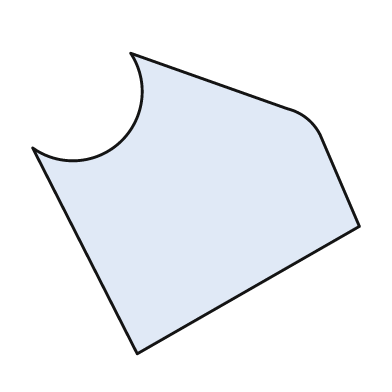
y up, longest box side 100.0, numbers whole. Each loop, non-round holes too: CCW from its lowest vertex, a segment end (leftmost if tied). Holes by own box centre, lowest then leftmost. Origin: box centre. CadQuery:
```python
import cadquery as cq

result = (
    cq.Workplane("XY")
    .moveTo(-18.0, -46.0)
    .lineTo(50.0, -7.0)
    .lineTo(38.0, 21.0)
    .threePointArc((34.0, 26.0), (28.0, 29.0))
    .lineTo(-20.0, 46.0)
    .threePointArc((-23.0, 19.0), (-50.0, 17.0))
    .close()
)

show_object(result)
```